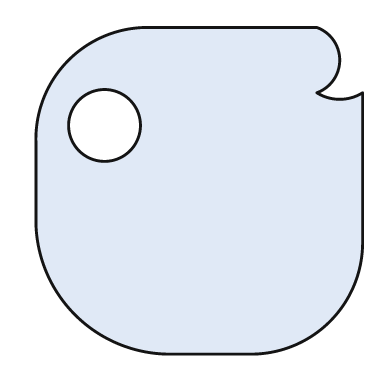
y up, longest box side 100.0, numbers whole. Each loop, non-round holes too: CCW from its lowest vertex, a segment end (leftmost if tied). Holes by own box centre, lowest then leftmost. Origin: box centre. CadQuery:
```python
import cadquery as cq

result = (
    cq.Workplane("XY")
    .moveTo(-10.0, -50.0)
    .lineTo(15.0, -50.0)
    .threePointArc((40.0, -40.0), (50.0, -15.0))
    .lineTo(50.0, 30.0)
    .threePointArc((43.0, 28.0), (36.0, 30.0))
    .threePointArc((43.0, 40.0), (36.0, 50.0))
    .lineTo(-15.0, 50.0)
    .threePointArc((-40.0, 40.0), (-50.0, 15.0))
    .lineTo(-50.0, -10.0)
    .threePointArc((-38.0, -38.0), (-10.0, -50.0))
    .close()
    .moveTo(-29.0, 20.0)
    .circle(11.0)
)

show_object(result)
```